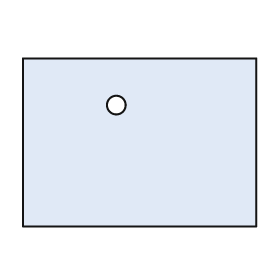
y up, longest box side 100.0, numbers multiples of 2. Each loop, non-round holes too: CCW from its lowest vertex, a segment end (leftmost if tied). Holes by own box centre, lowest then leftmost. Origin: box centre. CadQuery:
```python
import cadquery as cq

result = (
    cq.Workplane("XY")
    .moveTo(-50.0, -36.0)
    .lineTo(50.0, -36.0)
    .lineTo(50.0, 36.0)
    .lineTo(-50.0, 36.0)
    .close()
    .moveTo(-10.0, 16.0)
    .circle(4.0)
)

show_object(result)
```